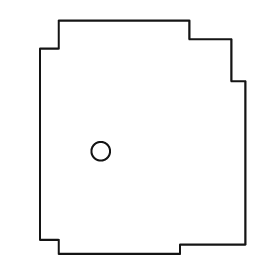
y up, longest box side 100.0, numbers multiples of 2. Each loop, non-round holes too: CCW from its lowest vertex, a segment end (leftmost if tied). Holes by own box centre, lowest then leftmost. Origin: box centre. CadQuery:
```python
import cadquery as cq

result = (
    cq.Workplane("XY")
    .moveTo(-36.0, -50.0)
    .lineTo(16.0, -50.0)
    .lineTo(16.0, -46.0)
    .lineTo(44.0, -46.0)
    .lineTo(44.0, 24.0)
    .lineTo(38.0, 24.0)
    .lineTo(38.0, 42.0)
    .lineTo(20.0, 42.0)
    .lineTo(20.0, 50.0)
    .lineTo(-36.0, 50.0)
    .lineTo(-36.0, 38.0)
    .lineTo(-44.0, 38.0)
    .lineTo(-44.0, -44.0)
    .lineTo(-36.0, -44.0)
    .close()
    .moveTo(-18.0, -6.0)
    .circle(4.0)
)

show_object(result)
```